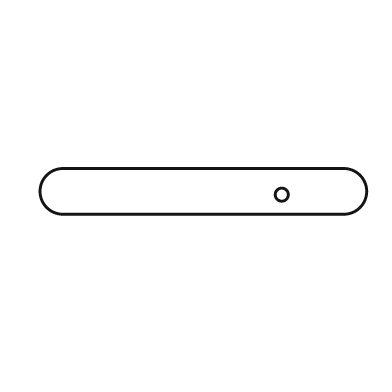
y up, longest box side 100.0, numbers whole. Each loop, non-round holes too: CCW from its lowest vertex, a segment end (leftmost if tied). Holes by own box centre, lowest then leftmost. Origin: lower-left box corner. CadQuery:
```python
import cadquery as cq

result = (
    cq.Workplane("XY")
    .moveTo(7.0, 0.0)
    .lineTo(93.0, 0.0)
    .threePointArc((100.0, 7.0), (93.0, 14.0))
    .lineTo(7.0, 14.0)
    .threePointArc((0.0, 7.0), (7.0, 0.0))
    .close()
    .moveTo(74.0, 6.0)
    .circle(2.0)
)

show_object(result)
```